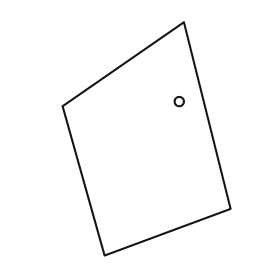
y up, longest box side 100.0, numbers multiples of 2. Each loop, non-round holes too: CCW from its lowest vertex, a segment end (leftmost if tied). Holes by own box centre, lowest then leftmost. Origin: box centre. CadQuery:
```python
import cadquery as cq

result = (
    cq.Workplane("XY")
    .moveTo(-18.0, -50.0)
    .lineTo(36.0, -30.0)
    .lineTo(16.0, 50.0)
    .lineTo(-36.0, 14.0)
    .close()
    .moveTo(14.0, 16.0)
    .circle(2.0)
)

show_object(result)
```